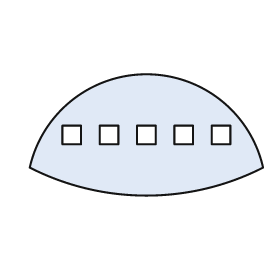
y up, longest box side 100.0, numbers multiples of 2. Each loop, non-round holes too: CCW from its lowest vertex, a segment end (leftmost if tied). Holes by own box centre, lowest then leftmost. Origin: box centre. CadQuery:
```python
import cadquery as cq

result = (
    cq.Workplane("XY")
    .moveTo(-50.0, -14.0)
    .threePointArc((0.0, -26.0), (50.0, -14.0))
    .threePointArc((0.0, 26.0), (-50.0, -14.0))
    .close()
    .moveTo(-36.0, -4.0)
    .lineTo(-28.0, -4.0)
    .lineTo(-28.0, 4.0)
    .lineTo(-36.0, 4.0)
    .close()
    .moveTo(-20.0, -4.0)
    .lineTo(-12.0, -4.0)
    .lineTo(-12.0, 4.0)
    .lineTo(-20.0, 4.0)
    .close()
    .moveTo(-4.0, -4.0)
    .lineTo(4.0, -4.0)
    .lineTo(4.0, 4.0)
    .lineTo(-4.0, 4.0)
    .close()
    .moveTo(12.0, -4.0)
    .lineTo(20.0, -4.0)
    .lineTo(20.0, 4.0)
    .lineTo(12.0, 4.0)
    .close()
    .moveTo(28.0, -4.0)
    .lineTo(36.0, -4.0)
    .lineTo(36.0, 4.0)
    .lineTo(28.0, 4.0)
    .close()
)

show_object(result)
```